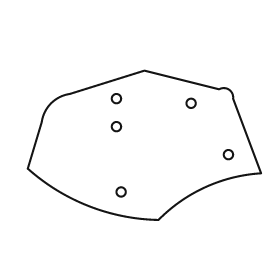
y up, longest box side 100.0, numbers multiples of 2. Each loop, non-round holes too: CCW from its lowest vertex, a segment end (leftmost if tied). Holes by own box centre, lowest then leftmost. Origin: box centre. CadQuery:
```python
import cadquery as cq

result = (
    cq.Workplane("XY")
    .moveTo(6.0, -32.0)
    .threePointArc((26.0, -18.0), (50.0, -12.0))
    .lineTo(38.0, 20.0)
    .threePointArc((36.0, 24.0), (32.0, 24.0))
    .lineTo(0.0, 32.0)
    .lineTo(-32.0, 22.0)
    .threePointArc((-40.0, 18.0), (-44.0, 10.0))
    .lineTo(-50.0, -10.0)
    .threePointArc((-24.0, -26.0), (6.0, -32.0))
    .close()
    .moveTo(-10.0, -20.0)
    .circle(2.0)
    .moveTo(36.0, -4.0)
    .circle(2.0)
    .moveTo(-12.0, 8.0)
    .circle(2.0)
    .moveTo(20.0, 18.0)
    .circle(2.0)
    .moveTo(-12.0, 20.0)
    .circle(2.0)
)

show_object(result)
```